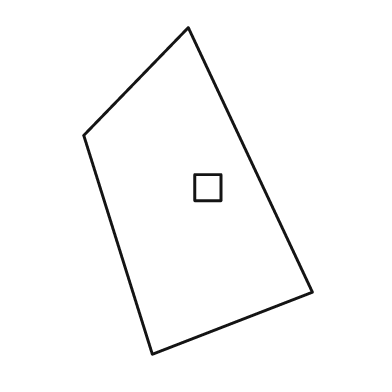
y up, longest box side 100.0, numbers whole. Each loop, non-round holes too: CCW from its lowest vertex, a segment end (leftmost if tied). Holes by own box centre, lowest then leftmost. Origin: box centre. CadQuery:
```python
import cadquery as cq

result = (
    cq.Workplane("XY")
    .moveTo(-14.0, -50.0)
    .lineTo(35.0, -31.0)
    .lineTo(-3.0, 50.0)
    .lineTo(-35.0, 17.0)
    .close()
    .moveTo(-1.0, -3.0)
    .lineTo(7.0, -3.0)
    .lineTo(7.0, 5.0)
    .lineTo(-1.0, 5.0)
    .close()
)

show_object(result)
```